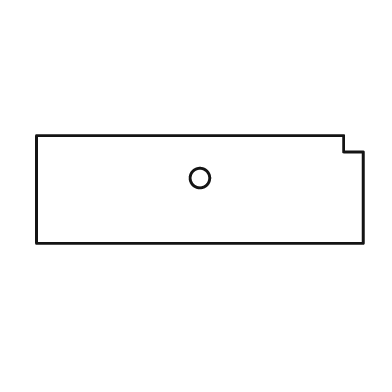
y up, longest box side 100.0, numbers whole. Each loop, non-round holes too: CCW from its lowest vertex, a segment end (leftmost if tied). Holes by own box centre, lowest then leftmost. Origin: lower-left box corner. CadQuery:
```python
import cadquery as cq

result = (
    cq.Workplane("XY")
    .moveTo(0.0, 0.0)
    .lineTo(100.0, 0.0)
    .lineTo(100.0, 28.0)
    .lineTo(94.0, 28.0)
    .lineTo(94.0, 33.0)
    .lineTo(0.0, 33.0)
    .close()
    .moveTo(50.0, 20.0)
    .circle(3.0)
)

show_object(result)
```